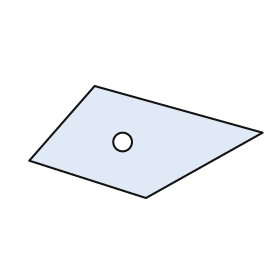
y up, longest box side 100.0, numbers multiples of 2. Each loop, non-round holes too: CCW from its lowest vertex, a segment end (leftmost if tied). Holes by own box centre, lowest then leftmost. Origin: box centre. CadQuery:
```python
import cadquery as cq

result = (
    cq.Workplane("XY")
    .moveTo(0.0, -24.0)
    .lineTo(50.0, 4.0)
    .lineTo(-22.0, 24.0)
    .lineTo(-50.0, -8.0)
    .close()
    .moveTo(-10.0, 0.0)
    .circle(4.0)
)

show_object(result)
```